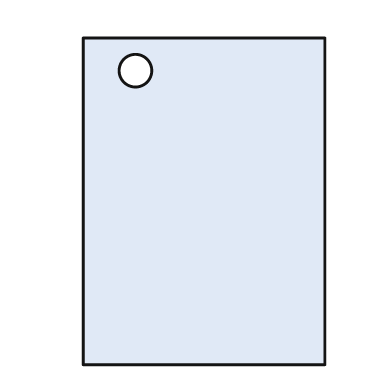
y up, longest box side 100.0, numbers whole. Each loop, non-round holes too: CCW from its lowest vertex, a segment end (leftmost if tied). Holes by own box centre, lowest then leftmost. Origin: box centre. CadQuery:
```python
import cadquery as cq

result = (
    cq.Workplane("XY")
    .moveTo(-37.0, -50.0)
    .lineTo(37.0, -50.0)
    .lineTo(37.0, 50.0)
    .lineTo(-37.0, 50.0)
    .close()
    .moveTo(-21.0, 40.0)
    .circle(5.0)
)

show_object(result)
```